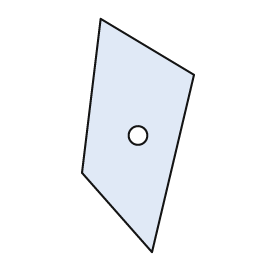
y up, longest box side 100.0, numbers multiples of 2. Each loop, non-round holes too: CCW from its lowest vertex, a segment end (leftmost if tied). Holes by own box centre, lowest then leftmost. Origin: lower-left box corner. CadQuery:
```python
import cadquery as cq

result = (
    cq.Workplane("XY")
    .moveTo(30.0, 0.0)
    .lineTo(48.0, 76.0)
    .lineTo(8.0, 100.0)
    .lineTo(0.0, 34.0)
    .close()
    .moveTo(24.0, 50.0)
    .circle(4.0)
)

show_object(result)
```